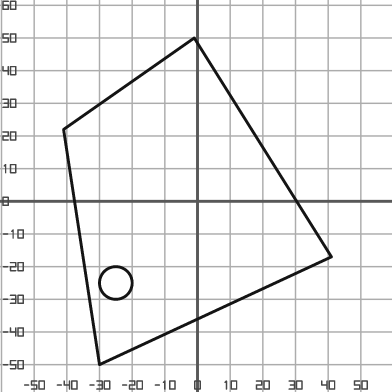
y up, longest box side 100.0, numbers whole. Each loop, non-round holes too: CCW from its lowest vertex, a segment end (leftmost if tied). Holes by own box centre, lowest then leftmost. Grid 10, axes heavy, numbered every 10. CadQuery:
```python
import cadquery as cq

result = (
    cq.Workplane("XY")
    .moveTo(-30.0, -50.0)
    .lineTo(41.0, -17.0)
    .lineTo(-1.0, 50.0)
    .lineTo(-41.0, 22.0)
    .close()
    .moveTo(-25.0, -25.0)
    .circle(5.0)
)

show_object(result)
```